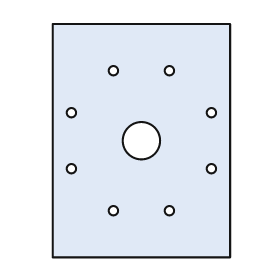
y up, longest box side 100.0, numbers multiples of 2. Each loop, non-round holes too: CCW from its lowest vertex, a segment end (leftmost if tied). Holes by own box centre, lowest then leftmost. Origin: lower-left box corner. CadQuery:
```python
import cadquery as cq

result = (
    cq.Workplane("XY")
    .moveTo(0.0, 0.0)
    .lineTo(76.0, 0.0)
    .lineTo(76.0, 100.0)
    .lineTo(0.0, 100.0)
    .close()
    .moveTo(26.0, 20.0)
    .circle(2.0)
    .moveTo(50.0, 20.0)
    .circle(2.0)
    .moveTo(8.0, 38.0)
    .circle(2.0)
    .moveTo(68.0, 38.0)
    .circle(2.0)
    .moveTo(38.0, 50.0)
    .circle(8.0)
    .moveTo(8.0, 62.0)
    .circle(2.0)
    .moveTo(68.0, 62.0)
    .circle(2.0)
    .moveTo(26.0, 80.0)
    .circle(2.0)
    .moveTo(50.0, 80.0)
    .circle(2.0)
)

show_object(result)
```